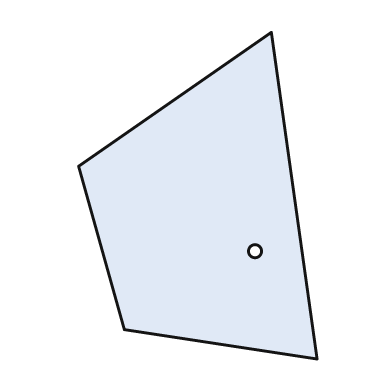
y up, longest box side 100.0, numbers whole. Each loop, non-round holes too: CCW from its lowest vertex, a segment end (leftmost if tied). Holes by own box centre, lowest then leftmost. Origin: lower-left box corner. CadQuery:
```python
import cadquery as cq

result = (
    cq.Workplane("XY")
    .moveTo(73.0, 0.0)
    .lineTo(59.0, 100.0)
    .lineTo(0.0, 59.0)
    .lineTo(14.0, 9.0)
    .close()
    .moveTo(54.0, 33.0)
    .circle(2.0)
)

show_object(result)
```